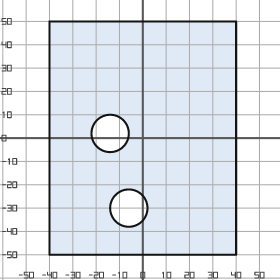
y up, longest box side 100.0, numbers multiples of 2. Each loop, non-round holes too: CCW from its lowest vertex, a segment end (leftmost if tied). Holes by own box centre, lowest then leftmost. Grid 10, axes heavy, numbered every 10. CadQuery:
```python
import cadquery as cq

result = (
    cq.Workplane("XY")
    .moveTo(-40.0, -50.0)
    .lineTo(40.0, -50.0)
    .lineTo(40.0, 50.0)
    .lineTo(-40.0, 50.0)
    .close()
    .moveTo(-6.0, -30.0)
    .circle(8.0)
    .moveTo(-14.0, 2.0)
    .circle(8.0)
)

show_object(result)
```